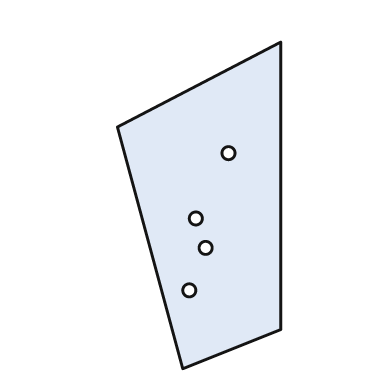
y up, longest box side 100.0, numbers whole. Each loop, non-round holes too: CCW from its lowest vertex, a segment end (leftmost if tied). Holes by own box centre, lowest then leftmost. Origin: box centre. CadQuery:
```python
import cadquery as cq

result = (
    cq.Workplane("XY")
    .moveTo(-5.0, -50.0)
    .lineTo(25.0, -38.0)
    .lineTo(25.0, 50.0)
    .lineTo(-25.0, 24.0)
    .close()
    .moveTo(-3.0, -26.0)
    .circle(2.0)
    .moveTo(2.0, -13.0)
    .circle(2.0)
    .moveTo(-1.0, -4.0)
    .circle(2.0)
    .moveTo(9.0, 16.0)
    .circle(2.0)
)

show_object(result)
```